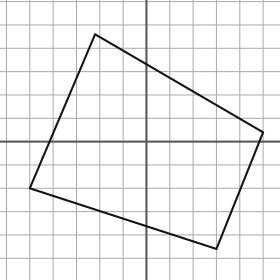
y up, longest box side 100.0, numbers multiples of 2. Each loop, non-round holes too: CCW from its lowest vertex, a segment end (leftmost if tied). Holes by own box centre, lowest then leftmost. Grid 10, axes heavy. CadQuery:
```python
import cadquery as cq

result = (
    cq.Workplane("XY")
    .moveTo(30.0, -46.0)
    .lineTo(50.0, 4.0)
    .lineTo(-22.0, 46.0)
    .lineTo(-50.0, -20.0)
    .close()
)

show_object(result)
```